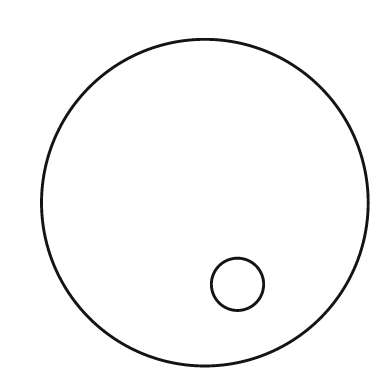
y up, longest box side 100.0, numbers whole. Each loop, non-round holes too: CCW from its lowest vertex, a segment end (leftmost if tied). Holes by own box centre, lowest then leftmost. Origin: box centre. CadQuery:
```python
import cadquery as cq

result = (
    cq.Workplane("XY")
    .moveTo(0.0, 0.0)
    .circle(50.0)
    .moveTo(10.0, -25.0)
    .circle(8.0)
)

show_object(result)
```